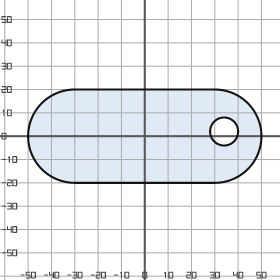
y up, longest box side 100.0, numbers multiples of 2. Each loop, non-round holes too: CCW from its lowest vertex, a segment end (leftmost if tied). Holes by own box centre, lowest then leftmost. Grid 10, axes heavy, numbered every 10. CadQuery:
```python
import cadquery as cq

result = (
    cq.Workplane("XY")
    .moveTo(-30.0, -20.0)
    .lineTo(30.0, -20.0)
    .threePointArc((50.0, 0.0), (30.0, 20.0))
    .lineTo(-30.0, 20.0)
    .threePointArc((-50.0, 0.0), (-30.0, -20.0))
    .close()
    .moveTo(34.0, 2.0)
    .circle(6.0)
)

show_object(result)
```